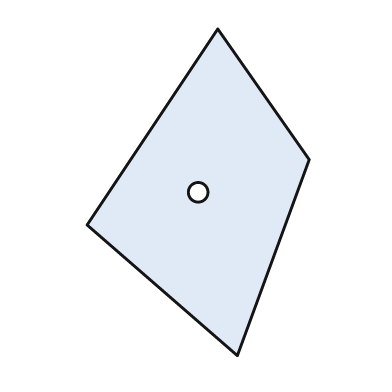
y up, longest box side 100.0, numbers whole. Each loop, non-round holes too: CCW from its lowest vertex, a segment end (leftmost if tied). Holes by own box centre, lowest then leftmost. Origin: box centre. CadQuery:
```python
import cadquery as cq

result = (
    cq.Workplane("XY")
    .moveTo(12.0, -50.0)
    .lineTo(34.0, 10.0)
    .lineTo(6.0, 50.0)
    .lineTo(-34.0, -10.0)
    .close()
    .moveTo(0.0, 0.0)
    .circle(3.0)
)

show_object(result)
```